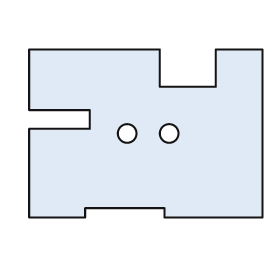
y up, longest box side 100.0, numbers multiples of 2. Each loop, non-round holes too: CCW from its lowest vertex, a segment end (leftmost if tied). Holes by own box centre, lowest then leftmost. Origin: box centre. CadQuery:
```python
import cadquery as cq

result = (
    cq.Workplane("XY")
    .moveTo(-50.0, -36.0)
    .lineTo(-26.0, -36.0)
    .lineTo(-26.0, -32.0)
    .lineTo(8.0, -32.0)
    .lineTo(8.0, -36.0)
    .lineTo(50.0, -36.0)
    .lineTo(50.0, 36.0)
    .lineTo(30.0, 36.0)
    .lineTo(30.0, 20.0)
    .lineTo(6.0, 20.0)
    .lineTo(6.0, 36.0)
    .lineTo(-50.0, 36.0)
    .lineTo(-50.0, 10.0)
    .lineTo(-24.0, 10.0)
    .lineTo(-24.0, 2.0)
    .lineTo(-50.0, 2.0)
    .close()
    .moveTo(-8.0, 0.0)
    .circle(4.0)
    .moveTo(10.0, 0.0)
    .circle(4.0)
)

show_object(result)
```